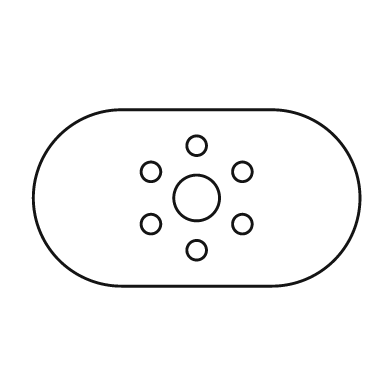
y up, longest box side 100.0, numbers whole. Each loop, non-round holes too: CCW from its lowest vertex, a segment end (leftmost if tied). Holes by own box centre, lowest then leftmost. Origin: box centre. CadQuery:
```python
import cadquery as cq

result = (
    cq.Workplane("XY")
    .moveTo(-23.0, -27.0)
    .lineTo(23.0, -27.0)
    .threePointArc((50.0, 0.0), (23.0, 27.0))
    .lineTo(-23.0, 27.0)
    .threePointArc((-50.0, 0.0), (-23.0, -27.0))
    .close()
    .moveTo(0.0, -16.0)
    .circle(3.0)
    .moveTo(-14.0, -8.0)
    .circle(3.0)
    .moveTo(14.0, -8.0)
    .circle(3.0)
    .moveTo(0.0, 0.0)
    .circle(7.0)
    .moveTo(-14.0, 8.0)
    .circle(3.0)
    .moveTo(14.0, 8.0)
    .circle(3.0)
    .moveTo(0.0, 16.0)
    .circle(3.0)
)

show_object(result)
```